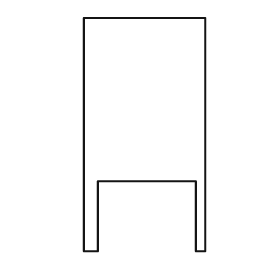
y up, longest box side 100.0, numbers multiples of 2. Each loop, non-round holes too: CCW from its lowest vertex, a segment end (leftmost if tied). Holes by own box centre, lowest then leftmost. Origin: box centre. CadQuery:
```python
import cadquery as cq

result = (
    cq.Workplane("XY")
    .moveTo(-26.0, -50.0)
    .lineTo(-20.0, -50.0)
    .lineTo(-20.0, -20.0)
    .lineTo(22.0, -20.0)
    .lineTo(22.0, -50.0)
    .lineTo(26.0, -50.0)
    .lineTo(26.0, 50.0)
    .lineTo(-26.0, 50.0)
    .close()
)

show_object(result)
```